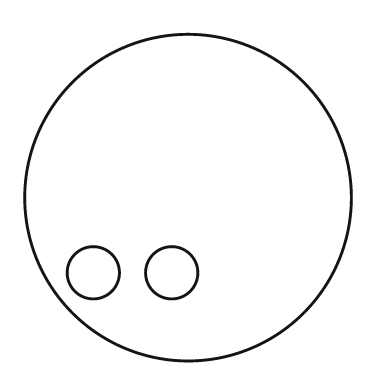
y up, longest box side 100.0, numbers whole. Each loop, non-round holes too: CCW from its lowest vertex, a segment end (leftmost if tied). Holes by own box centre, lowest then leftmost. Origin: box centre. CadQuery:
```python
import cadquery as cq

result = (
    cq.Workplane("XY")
    .moveTo(0.0, 0.0)
    .circle(50.0)
    .moveTo(-29.0, -23.0)
    .circle(8.0)
    .moveTo(-5.0, -23.0)
    .circle(8.0)
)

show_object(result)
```